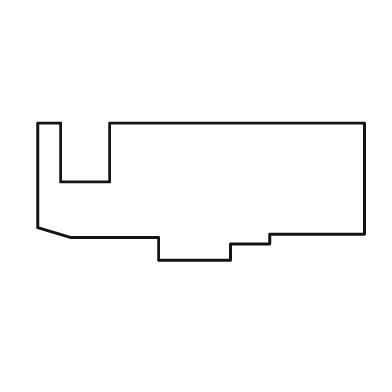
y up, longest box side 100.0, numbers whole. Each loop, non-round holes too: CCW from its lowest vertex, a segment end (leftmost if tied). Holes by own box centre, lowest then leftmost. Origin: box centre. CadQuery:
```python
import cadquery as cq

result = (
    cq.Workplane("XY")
    .moveTo(-13.0, -21.0)
    .lineTo(9.0, -21.0)
    .lineTo(9.0, -16.0)
    .lineTo(21.0, -16.0)
    .lineTo(21.0, -13.0)
    .lineTo(50.0, -13.0)
    .lineTo(50.0, 21.0)
    .lineTo(-28.0, 21.0)
    .lineTo(-28.0, 3.0)
    .lineTo(-43.0, 3.0)
    .lineTo(-43.0, 21.0)
    .lineTo(-50.0, 21.0)
    .lineTo(-50.0, -11.0)
    .lineTo(-40.0, -14.0)
    .lineTo(-13.0, -14.0)
    .close()
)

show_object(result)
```